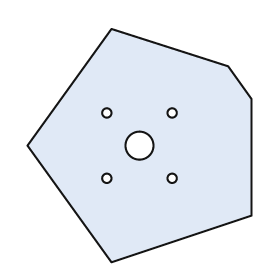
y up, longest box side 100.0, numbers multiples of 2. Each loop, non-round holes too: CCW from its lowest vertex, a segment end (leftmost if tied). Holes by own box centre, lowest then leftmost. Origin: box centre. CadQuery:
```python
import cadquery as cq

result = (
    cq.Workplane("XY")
    .moveTo(-12.0, -50.0)
    .lineTo(48.0, -30.0)
    .lineTo(48.0, 20.0)
    .lineTo(38.0, 34.0)
    .lineTo(-12.0, 50.0)
    .lineTo(-48.0, 0.0)
    .close()
    .moveTo(-14.0, -14.0)
    .circle(2.0)
    .moveTo(14.0, -14.0)
    .circle(2.0)
    .moveTo(0.0, 0.0)
    .circle(6.0)
    .moveTo(-14.0, 14.0)
    .circle(2.0)
    .moveTo(14.0, 14.0)
    .circle(2.0)
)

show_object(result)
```